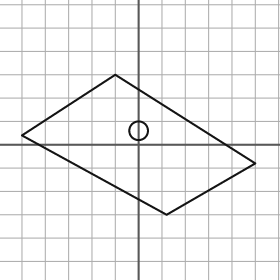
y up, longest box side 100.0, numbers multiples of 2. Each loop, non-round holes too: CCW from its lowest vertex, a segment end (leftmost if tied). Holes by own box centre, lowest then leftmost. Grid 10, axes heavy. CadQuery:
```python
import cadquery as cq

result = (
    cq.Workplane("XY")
    .moveTo(12.0, -30.0)
    .lineTo(50.0, -8.0)
    .lineTo(-10.0, 30.0)
    .lineTo(-50.0, 4.0)
    .close()
    .moveTo(0.0, 6.0)
    .circle(4.0)
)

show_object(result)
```